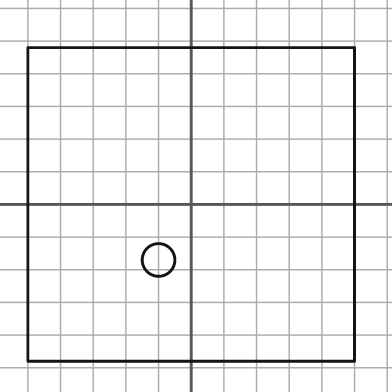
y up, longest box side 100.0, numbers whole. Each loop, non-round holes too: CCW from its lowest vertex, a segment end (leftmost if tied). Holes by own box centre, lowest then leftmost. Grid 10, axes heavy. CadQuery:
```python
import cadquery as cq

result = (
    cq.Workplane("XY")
    .moveTo(-50.0, -48.0)
    .lineTo(50.0, -48.0)
    .lineTo(50.0, 48.0)
    .lineTo(-50.0, 48.0)
    .close()
    .moveTo(-10.0, -17.0)
    .circle(5.0)
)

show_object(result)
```